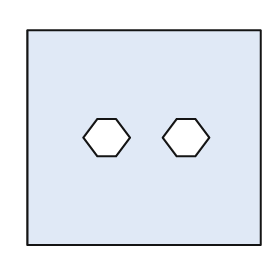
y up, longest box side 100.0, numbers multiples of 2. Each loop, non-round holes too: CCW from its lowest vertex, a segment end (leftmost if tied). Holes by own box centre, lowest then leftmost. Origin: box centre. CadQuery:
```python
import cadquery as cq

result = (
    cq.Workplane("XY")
    .moveTo(-50.0, -46.0)
    .lineTo(50.0, -46.0)
    .lineTo(50.0, 46.0)
    .lineTo(-50.0, 46.0)
    .close()
    .moveTo(-20.0, -8.0)
    .lineTo(-12.0, -8.0)
    .lineTo(-6.0, 0.0)
    .lineTo(-12.0, 8.0)
    .lineTo(-20.0, 8.0)
    .lineTo(-26.0, 0.0)
    .close()
    .moveTo(14.0, -8.0)
    .lineTo(22.0, -8.0)
    .lineTo(28.0, 0.0)
    .lineTo(22.0, 8.0)
    .lineTo(14.0, 8.0)
    .lineTo(8.0, 0.0)
    .close()
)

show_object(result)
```